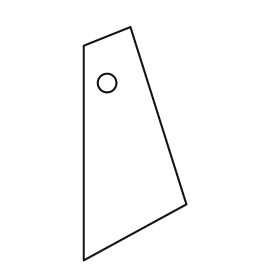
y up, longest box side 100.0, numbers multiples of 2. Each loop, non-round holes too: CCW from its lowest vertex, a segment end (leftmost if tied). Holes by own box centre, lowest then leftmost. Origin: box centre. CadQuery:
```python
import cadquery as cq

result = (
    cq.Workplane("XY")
    .moveTo(-22.0, -50.0)
    .lineTo(22.0, -26.0)
    .lineTo(-2.0, 50.0)
    .lineTo(-22.0, 42.0)
    .close()
    .moveTo(-12.0, 26.0)
    .circle(4.0)
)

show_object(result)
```